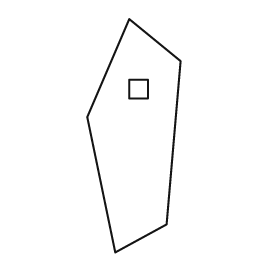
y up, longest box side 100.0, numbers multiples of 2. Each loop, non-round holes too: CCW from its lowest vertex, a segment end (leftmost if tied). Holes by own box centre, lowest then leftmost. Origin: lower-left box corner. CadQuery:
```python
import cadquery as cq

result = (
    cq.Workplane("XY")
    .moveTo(12.0, 0.0)
    .lineTo(34.0, 12.0)
    .lineTo(40.0, 82.0)
    .lineTo(18.0, 100.0)
    .lineTo(0.0, 58.0)
    .close()
    .moveTo(18.0, 66.0)
    .lineTo(26.0, 66.0)
    .lineTo(26.0, 74.0)
    .lineTo(18.0, 74.0)
    .close()
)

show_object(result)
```